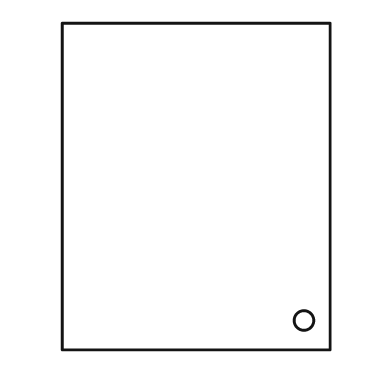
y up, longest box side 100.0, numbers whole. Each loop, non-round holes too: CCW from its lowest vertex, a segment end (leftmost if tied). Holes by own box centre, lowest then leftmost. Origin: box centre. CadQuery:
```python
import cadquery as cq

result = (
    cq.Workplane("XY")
    .moveTo(-41.0, -50.0)
    .lineTo(41.0, -50.0)
    .lineTo(41.0, 50.0)
    .lineTo(-41.0, 50.0)
    .close()
    .moveTo(33.0, -41.0)
    .circle(3.0)
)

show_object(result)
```